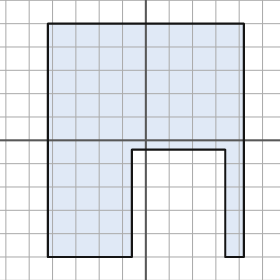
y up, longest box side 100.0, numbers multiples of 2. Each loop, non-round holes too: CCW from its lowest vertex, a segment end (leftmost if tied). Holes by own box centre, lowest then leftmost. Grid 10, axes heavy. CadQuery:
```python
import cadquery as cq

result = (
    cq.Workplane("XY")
    .moveTo(-42.0, -50.0)
    .lineTo(-6.0, -50.0)
    .lineTo(-6.0, -4.0)
    .lineTo(34.0, -4.0)
    .lineTo(34.0, -50.0)
    .lineTo(42.0, -50.0)
    .lineTo(42.0, 50.0)
    .lineTo(-42.0, 50.0)
    .close()
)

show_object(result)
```